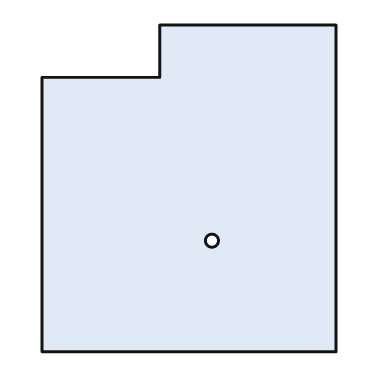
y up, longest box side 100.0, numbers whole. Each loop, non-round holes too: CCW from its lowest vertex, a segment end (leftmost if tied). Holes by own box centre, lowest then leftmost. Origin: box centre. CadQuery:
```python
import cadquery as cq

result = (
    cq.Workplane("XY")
    .moveTo(-45.0, -50.0)
    .lineTo(45.0, -50.0)
    .lineTo(45.0, 50.0)
    .lineTo(-9.0, 50.0)
    .lineTo(-9.0, 34.0)
    .lineTo(-45.0, 34.0)
    .close()
    .moveTo(7.0, -16.0)
    .circle(2.0)
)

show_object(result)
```